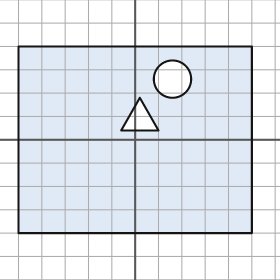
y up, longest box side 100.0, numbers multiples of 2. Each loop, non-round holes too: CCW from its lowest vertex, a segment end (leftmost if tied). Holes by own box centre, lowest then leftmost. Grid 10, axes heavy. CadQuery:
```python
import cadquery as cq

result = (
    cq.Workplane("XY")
    .moveTo(-50.0, -40.0)
    .lineTo(50.0, -40.0)
    .lineTo(50.0, 40.0)
    .lineTo(-50.0, 40.0)
    .close()
    .moveTo(-6.0, 4.0)
    .lineTo(10.0, 4.0)
    .lineTo(2.0, 18.0)
    .close()
    .moveTo(16.0, 26.0)
    .circle(8.0)
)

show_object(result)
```